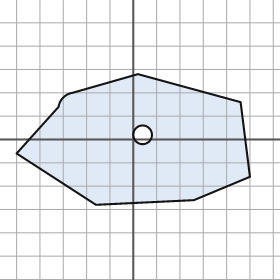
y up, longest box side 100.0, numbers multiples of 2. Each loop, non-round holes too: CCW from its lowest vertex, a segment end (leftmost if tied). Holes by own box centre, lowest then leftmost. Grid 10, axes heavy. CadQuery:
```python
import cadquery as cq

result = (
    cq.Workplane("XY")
    .moveTo(-16.0, -28.0)
    .lineTo(26.0, -26.0)
    .lineTo(50.0, -16.0)
    .lineTo(46.0, 16.0)
    .lineTo(2.0, 28.0)
    .lineTo(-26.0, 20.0)
    .threePointArc((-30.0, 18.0), (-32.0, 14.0))
    .lineTo(-50.0, -6.0)
    .close()
    .moveTo(4.0, 2.0)
    .circle(4.0)
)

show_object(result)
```